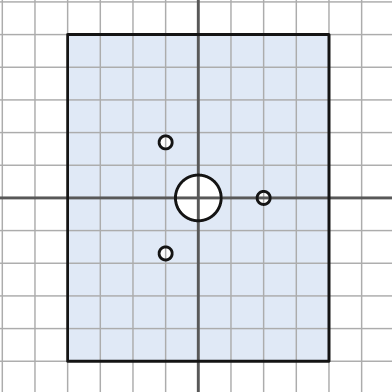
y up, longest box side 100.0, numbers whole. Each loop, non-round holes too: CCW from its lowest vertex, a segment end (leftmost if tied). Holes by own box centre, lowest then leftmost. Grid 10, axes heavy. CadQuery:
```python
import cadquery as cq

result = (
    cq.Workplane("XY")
    .moveTo(-40.0, -50.0)
    .lineTo(40.0, -50.0)
    .lineTo(40.0, 50.0)
    .lineTo(-40.0, 50.0)
    .close()
    .moveTo(-10.0, -17.0)
    .circle(2.0)
    .moveTo(0.0, 0.0)
    .circle(7.0)
    .moveTo(20.0, 0.0)
    .circle(2.0)
    .moveTo(-10.0, 17.0)
    .circle(2.0)
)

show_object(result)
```